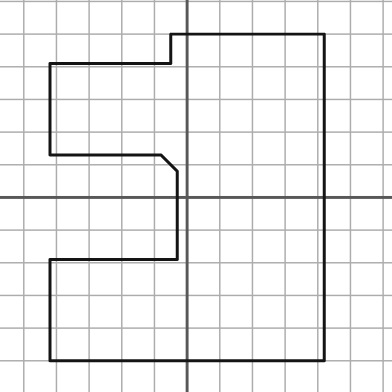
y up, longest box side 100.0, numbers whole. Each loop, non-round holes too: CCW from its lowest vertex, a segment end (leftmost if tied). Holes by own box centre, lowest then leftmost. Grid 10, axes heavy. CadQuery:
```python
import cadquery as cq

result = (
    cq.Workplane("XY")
    .moveTo(-42.0, -50.0)
    .lineTo(42.0, -50.0)
    .lineTo(42.0, 50.0)
    .lineTo(-5.0, 50.0)
    .lineTo(-5.0, 41.0)
    .lineTo(-42.0, 41.0)
    .lineTo(-42.0, 13.0)
    .lineTo(-8.0, 13.0)
    .lineTo(-3.0, 8.0)
    .lineTo(-3.0, -19.0)
    .lineTo(-42.0, -19.0)
    .close()
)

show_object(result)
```